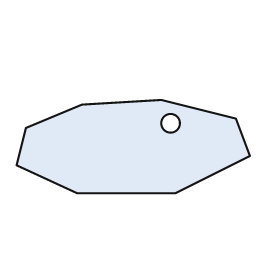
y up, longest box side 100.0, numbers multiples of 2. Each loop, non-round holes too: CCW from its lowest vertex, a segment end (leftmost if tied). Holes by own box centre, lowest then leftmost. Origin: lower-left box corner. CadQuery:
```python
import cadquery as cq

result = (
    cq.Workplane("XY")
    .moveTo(26.0, 0.0)
    .lineTo(68.0, 0.0)
    .lineTo(100.0, 16.0)
    .lineTo(94.0, 32.0)
    .lineTo(62.0, 40.0)
    .lineTo(28.0, 38.0)
    .lineTo(4.0, 28.0)
    .lineTo(0.0, 12.0)
    .close()
    .moveTo(66.0, 30.0)
    .circle(4.0)
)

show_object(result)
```